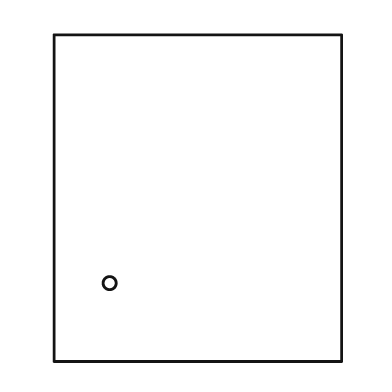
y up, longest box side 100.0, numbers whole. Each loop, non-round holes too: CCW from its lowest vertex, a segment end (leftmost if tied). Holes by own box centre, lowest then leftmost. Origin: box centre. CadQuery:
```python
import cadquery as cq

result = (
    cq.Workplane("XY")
    .moveTo(-44.0, -50.0)
    .lineTo(44.0, -50.0)
    .lineTo(44.0, 50.0)
    .lineTo(-44.0, 50.0)
    .close()
    .moveTo(-27.0, -26.0)
    .circle(2.0)
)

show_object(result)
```